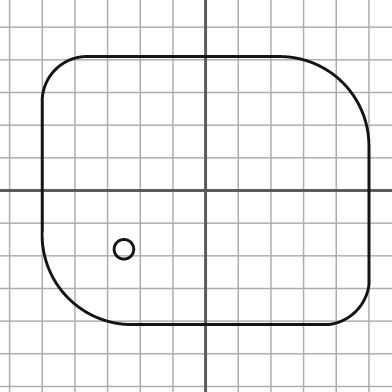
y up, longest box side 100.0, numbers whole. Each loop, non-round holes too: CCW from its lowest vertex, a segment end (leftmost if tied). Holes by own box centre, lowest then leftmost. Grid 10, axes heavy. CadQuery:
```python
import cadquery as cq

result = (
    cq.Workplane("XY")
    .moveTo(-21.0, -41.0)
    .lineTo(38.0, -41.0)
    .threePointArc((46.0, -37.0), (50.0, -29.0))
    .lineTo(50.0, 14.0)
    .threePointArc((42.0, 33.0), (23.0, 41.0))
    .lineTo(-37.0, 41.0)
    .threePointArc((-46.0, 37.0), (-50.0, 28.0))
    .lineTo(-50.0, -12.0)
    .threePointArc((-42.0, -33.0), (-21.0, -41.0))
    .close()
    .moveTo(-25.0, -18.0)
    .circle(3.0)
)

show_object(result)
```